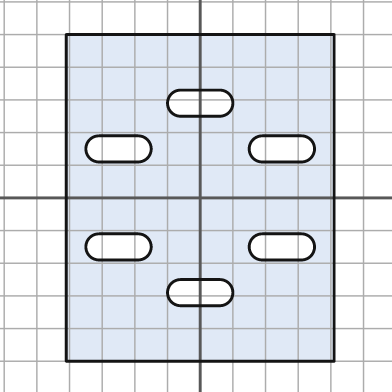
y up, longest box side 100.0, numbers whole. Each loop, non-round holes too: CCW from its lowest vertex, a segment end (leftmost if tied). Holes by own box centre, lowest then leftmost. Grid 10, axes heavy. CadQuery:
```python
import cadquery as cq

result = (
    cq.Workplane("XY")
    .moveTo(-41.0, -50.0)
    .lineTo(41.0, -50.0)
    .lineTo(41.0, 50.0)
    .lineTo(-41.0, 50.0)
    .close()
    .moveTo(-6.0, -33.0)
    .lineTo(6.0, -33.0)
    .threePointArc((10.0, -29.0), (6.0, -25.0))
    .lineTo(-6.0, -25.0)
    .threePointArc((-10.0, -29.0), (-6.0, -33.0))
    .close()
    .moveTo(-31.0, -19.0)
    .lineTo(-19.0, -19.0)
    .threePointArc((-15.0, -15.0), (-19.0, -11.0))
    .lineTo(-31.0, -11.0)
    .threePointArc((-35.0, -15.0), (-31.0, -19.0))
    .close()
    .moveTo(19.0, -19.0)
    .lineTo(31.0, -19.0)
    .threePointArc((35.0, -15.0), (31.0, -11.0))
    .lineTo(19.0, -11.0)
    .threePointArc((15.0, -15.0), (19.0, -19.0))
    .close()
    .moveTo(-31.0, 11.0)
    .lineTo(-19.0, 11.0)
    .threePointArc((-15.0, 15.0), (-19.0, 19.0))
    .lineTo(-31.0, 19.0)
    .threePointArc((-35.0, 15.0), (-31.0, 11.0))
    .close()
    .moveTo(19.0, 11.0)
    .lineTo(31.0, 11.0)
    .threePointArc((35.0, 15.0), (31.0, 19.0))
    .lineTo(19.0, 19.0)
    .threePointArc((15.0, 15.0), (19.0, 11.0))
    .close()
    .moveTo(-6.0, 25.0)
    .lineTo(6.0, 25.0)
    .threePointArc((10.0, 29.0), (6.0, 33.0))
    .lineTo(-6.0, 33.0)
    .threePointArc((-10.0, 29.0), (-6.0, 25.0))
    .close()
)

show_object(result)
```